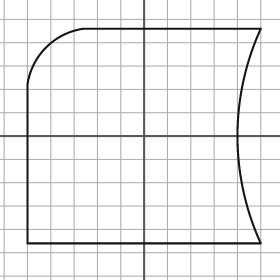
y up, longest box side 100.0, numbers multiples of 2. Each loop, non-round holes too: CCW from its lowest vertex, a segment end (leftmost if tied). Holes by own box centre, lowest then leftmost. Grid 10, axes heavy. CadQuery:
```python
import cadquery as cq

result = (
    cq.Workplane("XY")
    .moveTo(-50.0, -46.0)
    .lineTo(50.0, -46.0)
    .threePointArc((40.0, 0.0), (50.0, 46.0))
    .lineTo(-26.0, 46.0)
    .threePointArc((-42.0, 38.0), (-50.0, 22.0))
    .close()
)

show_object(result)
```